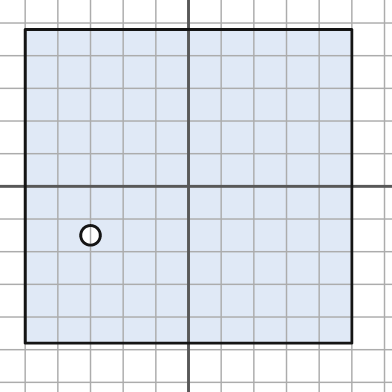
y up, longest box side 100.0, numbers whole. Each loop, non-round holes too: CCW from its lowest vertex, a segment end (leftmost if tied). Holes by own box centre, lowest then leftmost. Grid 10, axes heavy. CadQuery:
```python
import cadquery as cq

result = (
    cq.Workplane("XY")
    .moveTo(-50.0, -48.0)
    .lineTo(50.0, -48.0)
    .lineTo(50.0, 48.0)
    .lineTo(-50.0, 48.0)
    .close()
    .moveTo(-30.0, -15.0)
    .circle(3.0)
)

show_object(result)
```